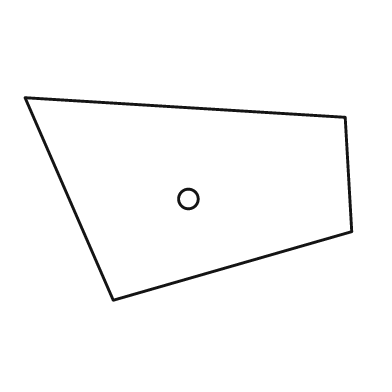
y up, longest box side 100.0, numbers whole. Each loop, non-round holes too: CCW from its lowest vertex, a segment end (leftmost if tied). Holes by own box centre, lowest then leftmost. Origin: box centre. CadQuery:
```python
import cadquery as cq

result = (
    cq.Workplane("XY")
    .moveTo(-23.0, -31.0)
    .lineTo(50.0, -10.0)
    .lineTo(48.0, 25.0)
    .lineTo(-50.0, 31.0)
    .close()
    .moveTo(0.0, 0.0)
    .circle(3.0)
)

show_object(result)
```